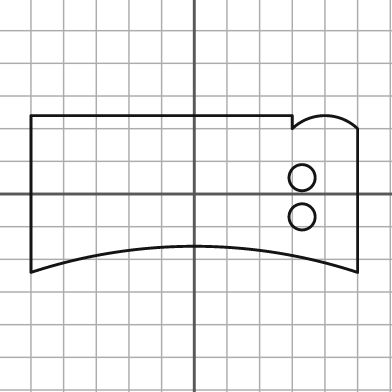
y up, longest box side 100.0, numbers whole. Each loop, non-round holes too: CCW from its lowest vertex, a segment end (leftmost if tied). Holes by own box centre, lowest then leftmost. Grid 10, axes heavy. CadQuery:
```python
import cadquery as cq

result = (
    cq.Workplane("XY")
    .moveTo(-50.0, -24.0)
    .threePointArc((0.0, -16.0), (50.0, -24.0))
    .lineTo(50.0, 20.0)
    .threePointArc((40.0, 24.0), (30.0, 20.0))
    .lineTo(30.0, 24.0)
    .lineTo(-50.0, 24.0)
    .close()
    .moveTo(33.0, -7.0)
    .circle(4.0)
    .moveTo(33.0, 5.0)
    .circle(4.0)
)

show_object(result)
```